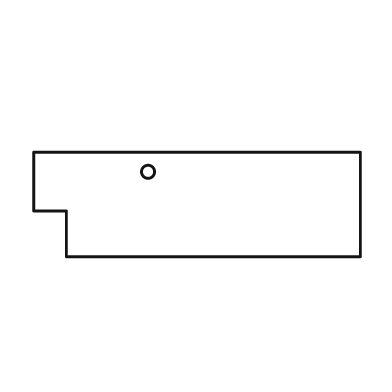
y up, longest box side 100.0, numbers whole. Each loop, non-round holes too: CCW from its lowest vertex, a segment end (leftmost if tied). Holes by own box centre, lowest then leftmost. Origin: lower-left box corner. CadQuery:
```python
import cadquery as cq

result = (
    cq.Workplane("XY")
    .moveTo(10.0, 0.0)
    .lineTo(100.0, 0.0)
    .lineTo(100.0, 32.0)
    .lineTo(0.0, 32.0)
    .lineTo(0.0, 14.0)
    .lineTo(10.0, 14.0)
    .close()
    .moveTo(35.0, 26.0)
    .circle(2.0)
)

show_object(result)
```